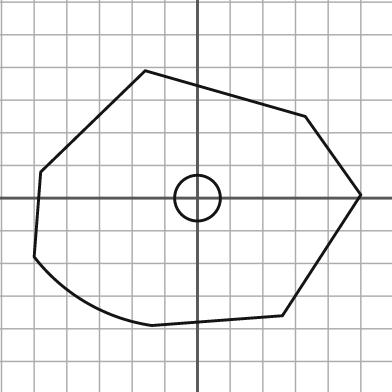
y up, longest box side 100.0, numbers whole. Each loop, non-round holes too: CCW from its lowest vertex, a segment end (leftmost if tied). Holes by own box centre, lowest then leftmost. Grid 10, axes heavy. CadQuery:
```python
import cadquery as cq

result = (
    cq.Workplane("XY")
    .moveTo(-14.0, -39.0)
    .lineTo(26.0, -36.0)
    .lineTo(50.0, 1.0)
    .lineTo(33.0, 25.0)
    .lineTo(-16.0, 39.0)
    .lineTo(-48.0, 8.0)
    .lineTo(-50.0, -18.0)
    .threePointArc((-34.0, -32.0), (-14.0, -39.0))
    .close()
    .moveTo(0.0, 0.0)
    .circle(7.0)
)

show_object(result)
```